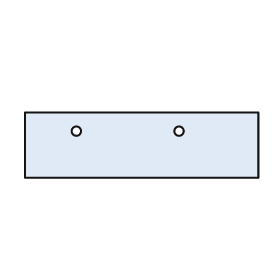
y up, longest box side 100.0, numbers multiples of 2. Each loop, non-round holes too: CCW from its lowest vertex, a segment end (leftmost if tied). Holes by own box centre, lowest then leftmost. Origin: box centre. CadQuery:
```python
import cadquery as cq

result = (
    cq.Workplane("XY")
    .moveTo(-50.0, -14.0)
    .lineTo(50.0, -14.0)
    .lineTo(50.0, 14.0)
    .lineTo(-50.0, 14.0)
    .close()
    .moveTo(-28.0, 6.0)
    .circle(2.0)
    .moveTo(16.0, 6.0)
    .circle(2.0)
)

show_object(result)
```